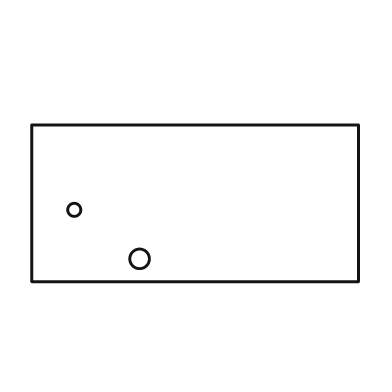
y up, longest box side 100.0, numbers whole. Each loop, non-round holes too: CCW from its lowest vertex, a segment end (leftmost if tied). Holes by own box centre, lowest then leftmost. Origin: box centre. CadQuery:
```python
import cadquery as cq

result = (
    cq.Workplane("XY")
    .moveTo(-50.0, -24.0)
    .lineTo(50.0, -24.0)
    .lineTo(50.0, 24.0)
    .lineTo(-50.0, 24.0)
    .close()
    .moveTo(-17.0, -17.0)
    .circle(3.0)
    .moveTo(-37.0, -2.0)
    .circle(2.0)
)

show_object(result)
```